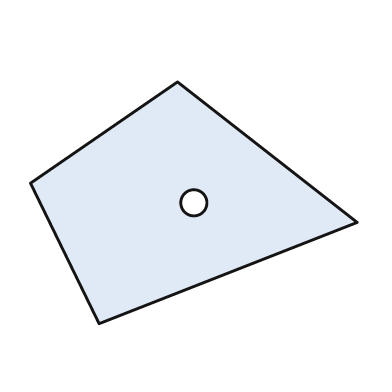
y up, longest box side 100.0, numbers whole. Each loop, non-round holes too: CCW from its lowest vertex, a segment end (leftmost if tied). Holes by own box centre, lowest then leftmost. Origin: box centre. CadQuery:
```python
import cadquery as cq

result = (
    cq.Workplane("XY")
    .moveTo(-29.0, -37.0)
    .lineTo(50.0, -6.0)
    .lineTo(-5.0, 37.0)
    .lineTo(-50.0, 6.0)
    .close()
    .moveTo(0.0, 0.0)
    .circle(4.0)
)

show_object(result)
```